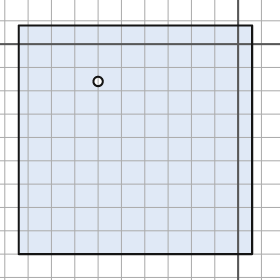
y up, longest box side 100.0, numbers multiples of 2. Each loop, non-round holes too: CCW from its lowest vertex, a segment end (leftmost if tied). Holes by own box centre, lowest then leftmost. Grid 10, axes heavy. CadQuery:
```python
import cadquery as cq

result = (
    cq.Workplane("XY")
    .moveTo(-94.0, -90.0)
    .lineTo(6.0, -90.0)
    .lineTo(6.0, 8.0)
    .lineTo(-94.0, 8.0)
    .close()
    .moveTo(-60.0, -16.0)
    .circle(2.0)
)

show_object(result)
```